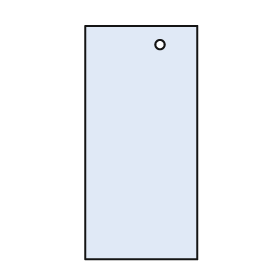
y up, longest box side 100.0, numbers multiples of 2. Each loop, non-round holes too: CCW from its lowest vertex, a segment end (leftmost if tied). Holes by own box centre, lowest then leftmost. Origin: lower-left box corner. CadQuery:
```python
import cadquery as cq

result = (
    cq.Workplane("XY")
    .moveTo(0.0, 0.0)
    .lineTo(48.0, 0.0)
    .lineTo(48.0, 100.0)
    .lineTo(0.0, 100.0)
    .close()
    .moveTo(32.0, 92.0)
    .circle(2.0)
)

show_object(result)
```